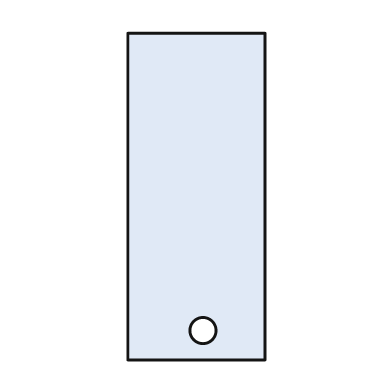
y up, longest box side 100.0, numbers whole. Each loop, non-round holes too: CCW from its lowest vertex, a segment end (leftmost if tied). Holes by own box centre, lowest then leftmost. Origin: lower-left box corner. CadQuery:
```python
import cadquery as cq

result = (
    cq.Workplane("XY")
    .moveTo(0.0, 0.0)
    .lineTo(42.0, 0.0)
    .lineTo(42.0, 100.0)
    .lineTo(0.0, 100.0)
    .close()
    .moveTo(23.0, 9.0)
    .circle(4.0)
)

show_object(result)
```